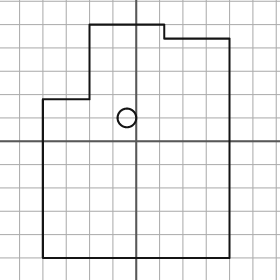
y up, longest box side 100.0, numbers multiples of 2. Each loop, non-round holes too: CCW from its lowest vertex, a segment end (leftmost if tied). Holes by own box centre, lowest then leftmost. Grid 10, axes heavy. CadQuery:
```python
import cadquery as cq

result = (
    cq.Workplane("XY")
    .moveTo(-40.0, -50.0)
    .lineTo(40.0, -50.0)
    .lineTo(40.0, 44.0)
    .lineTo(12.0, 44.0)
    .lineTo(12.0, 50.0)
    .lineTo(-20.0, 50.0)
    .lineTo(-20.0, 18.0)
    .lineTo(-40.0, 18.0)
    .close()
    .moveTo(-4.0, 10.0)
    .circle(4.0)
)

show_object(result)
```